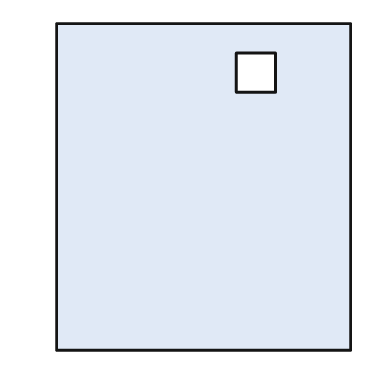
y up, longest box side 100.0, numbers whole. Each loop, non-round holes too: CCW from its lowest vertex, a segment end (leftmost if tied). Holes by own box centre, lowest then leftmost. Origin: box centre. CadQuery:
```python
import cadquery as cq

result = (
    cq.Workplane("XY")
    .moveTo(-45.0, -50.0)
    .lineTo(45.0, -50.0)
    .lineTo(45.0, 50.0)
    .lineTo(-45.0, 50.0)
    .close()
    .moveTo(10.0, 29.0)
    .lineTo(22.0, 29.0)
    .lineTo(22.0, 41.0)
    .lineTo(10.0, 41.0)
    .close()
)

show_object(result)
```